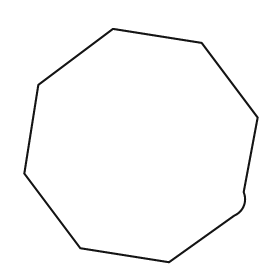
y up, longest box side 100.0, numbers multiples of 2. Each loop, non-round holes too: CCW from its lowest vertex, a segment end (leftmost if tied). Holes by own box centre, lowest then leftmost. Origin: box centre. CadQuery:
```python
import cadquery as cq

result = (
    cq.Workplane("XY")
    .moveTo(12.0, -50.0)
    .lineTo(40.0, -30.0)
    .threePointArc((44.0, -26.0), (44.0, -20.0))
    .lineTo(50.0, 12.0)
    .lineTo(26.0, 44.0)
    .lineTo(-12.0, 50.0)
    .lineTo(-44.0, 26.0)
    .lineTo(-50.0, -12.0)
    .lineTo(-26.0, -44.0)
    .close()
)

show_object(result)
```